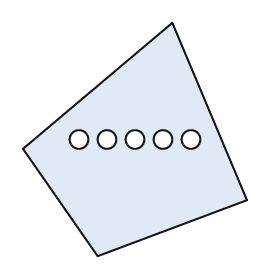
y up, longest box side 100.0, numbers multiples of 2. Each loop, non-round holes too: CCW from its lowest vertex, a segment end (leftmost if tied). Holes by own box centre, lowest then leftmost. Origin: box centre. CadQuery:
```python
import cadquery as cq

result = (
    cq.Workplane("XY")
    .moveTo(-16.0, -50.0)
    .lineTo(48.0, -26.0)
    .lineTo(16.0, 50.0)
    .lineTo(-48.0, -4.0)
    .close()
    .moveTo(-24.0, 0.0)
    .circle(4.0)
    .moveTo(-12.0, 0.0)
    .circle(4.0)
    .moveTo(0.0, 0.0)
    .circle(4.0)
    .moveTo(12.0, 0.0)
    .circle(4.0)
    .moveTo(24.0, 0.0)
    .circle(4.0)
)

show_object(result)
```